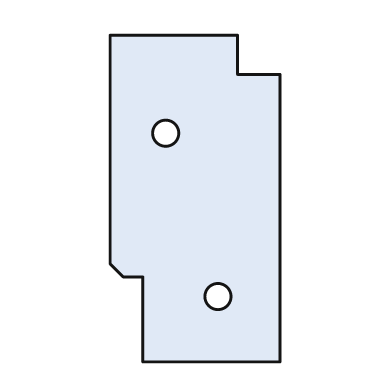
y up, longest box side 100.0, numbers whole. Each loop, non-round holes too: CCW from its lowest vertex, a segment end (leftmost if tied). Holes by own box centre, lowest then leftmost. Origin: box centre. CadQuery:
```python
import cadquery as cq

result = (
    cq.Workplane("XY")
    .moveTo(-16.0, -50.0)
    .lineTo(26.0, -50.0)
    .lineTo(26.0, 38.0)
    .lineTo(13.0, 38.0)
    .lineTo(13.0, 50.0)
    .lineTo(-26.0, 50.0)
    .lineTo(-26.0, -20.0)
    .lineTo(-22.0, -24.0)
    .lineTo(-16.0, -24.0)
    .close()
    .moveTo(7.0, -30.0)
    .circle(4.0)
    .moveTo(-9.0, 20.0)
    .circle(4.0)
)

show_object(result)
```